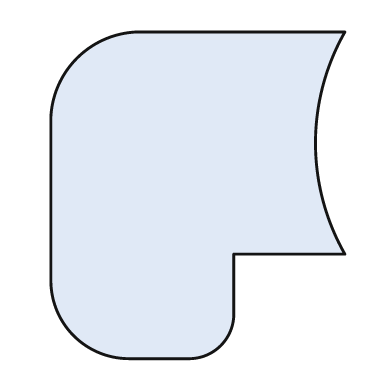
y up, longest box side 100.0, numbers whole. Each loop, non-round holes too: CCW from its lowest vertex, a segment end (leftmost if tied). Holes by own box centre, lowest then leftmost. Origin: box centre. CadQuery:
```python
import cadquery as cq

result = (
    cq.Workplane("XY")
    .moveTo(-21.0, -50.0)
    .lineTo(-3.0, -50.0)
    .threePointArc((7.0, -46.0), (11.0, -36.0))
    .lineTo(11.0, -18.0)
    .lineTo(45.0, -18.0)
    .threePointArc((36.0, 16.0), (45.0, 50.0))
    .lineTo(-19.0, 50.0)
    .threePointArc((-37.0, 42.0), (-45.0, 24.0))
    .lineTo(-45.0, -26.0)
    .threePointArc((-38.0, -43.0), (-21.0, -50.0))
    .close()
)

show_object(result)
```